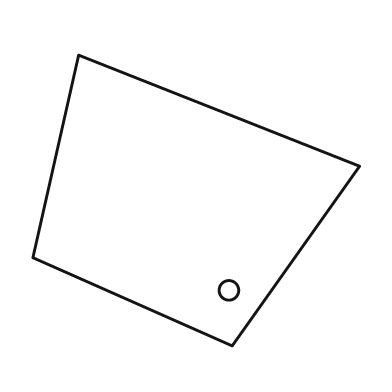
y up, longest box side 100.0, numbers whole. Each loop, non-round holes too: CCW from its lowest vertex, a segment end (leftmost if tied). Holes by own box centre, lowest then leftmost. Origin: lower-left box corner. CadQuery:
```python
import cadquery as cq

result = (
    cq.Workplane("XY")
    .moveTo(61.0, 0.0)
    .lineTo(100.0, 55.0)
    .lineTo(14.0, 89.0)
    .lineTo(0.0, 27.0)
    .close()
    .moveTo(60.0, 17.0)
    .circle(3.0)
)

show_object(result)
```